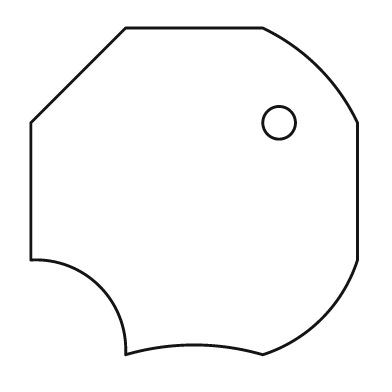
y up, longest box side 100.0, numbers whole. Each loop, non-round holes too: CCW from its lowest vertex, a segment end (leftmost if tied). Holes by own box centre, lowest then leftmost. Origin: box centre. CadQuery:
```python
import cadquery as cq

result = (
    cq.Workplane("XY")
    .moveTo(-21.0, -50.0)
    .threePointArc((0.0, -47.0), (21.0, -50.0))
    .threePointArc((39.0, -39.0), (50.0, -21.0))
    .lineTo(50.0, 21.0)
    .threePointArc((38.0, 38.0), (21.0, 50.0))
    .lineTo(-21.0, 50.0)
    .lineTo(-50.0, 21.0)
    .lineTo(-50.0, -21.0)
    .threePointArc((-29.0, -29.0), (-21.0, -50.0))
    .close()
    .moveTo(26.0, 21.0)
    .circle(5.0)
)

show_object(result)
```